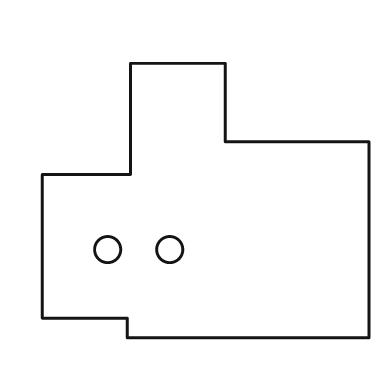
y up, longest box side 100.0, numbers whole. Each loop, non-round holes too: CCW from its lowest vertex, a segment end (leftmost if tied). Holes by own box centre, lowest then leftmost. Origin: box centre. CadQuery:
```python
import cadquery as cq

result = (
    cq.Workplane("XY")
    .moveTo(-24.0, -42.0)
    .lineTo(50.0, -42.0)
    .lineTo(50.0, 18.0)
    .lineTo(6.0, 18.0)
    .lineTo(6.0, 42.0)
    .lineTo(-23.0, 42.0)
    .lineTo(-23.0, 8.0)
    .lineTo(-50.0, 8.0)
    .lineTo(-50.0, -36.0)
    .lineTo(-24.0, -36.0)
    .close()
    .moveTo(-30.0, -15.0)
    .circle(4.0)
    .moveTo(-11.0, -15.0)
    .circle(4.0)
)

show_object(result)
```